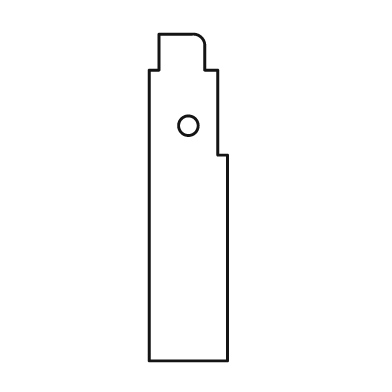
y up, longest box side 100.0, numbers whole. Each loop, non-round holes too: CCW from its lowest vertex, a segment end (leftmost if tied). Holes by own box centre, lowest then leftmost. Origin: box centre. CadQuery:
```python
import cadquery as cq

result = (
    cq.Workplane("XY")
    .moveTo(-12.0, -50.0)
    .lineTo(12.0, -50.0)
    .lineTo(12.0, 13.0)
    .lineTo(9.0, 13.0)
    .lineTo(9.0, 39.0)
    .lineTo(5.0, 39.0)
    .lineTo(5.0, 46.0)
    .threePointArc((4.0, 49.0), (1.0, 50.0))
    .lineTo(-9.0, 50.0)
    .lineTo(-9.0, 39.0)
    .lineTo(-12.0, 39.0)
    .close()
    .moveTo(0.0, 22.0)
    .circle(3.0)
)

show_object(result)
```